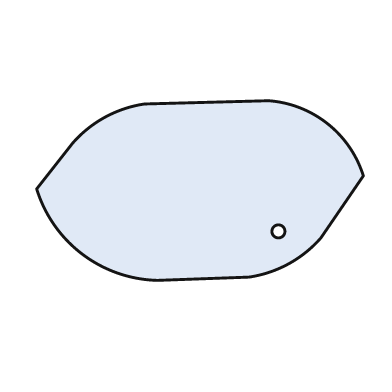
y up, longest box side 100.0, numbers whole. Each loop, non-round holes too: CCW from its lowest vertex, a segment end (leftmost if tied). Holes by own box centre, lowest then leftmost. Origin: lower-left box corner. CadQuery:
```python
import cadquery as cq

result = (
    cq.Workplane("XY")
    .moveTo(37.0, 0.0)
    .lineTo(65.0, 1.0)
    .threePointArc((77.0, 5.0), (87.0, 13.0))
    .lineTo(100.0, 32.0)
    .threePointArc((89.0, 48.0), (71.0, 55.0))
    .lineTo(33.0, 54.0)
    .threePointArc((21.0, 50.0), (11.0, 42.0))
    .lineTo(0.0, 28.0)
    .threePointArc((14.0, 8.0), (37.0, 0.0))
    .close()
    .moveTo(74.0, 15.0)
    .circle(2.0)
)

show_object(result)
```